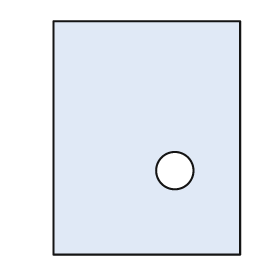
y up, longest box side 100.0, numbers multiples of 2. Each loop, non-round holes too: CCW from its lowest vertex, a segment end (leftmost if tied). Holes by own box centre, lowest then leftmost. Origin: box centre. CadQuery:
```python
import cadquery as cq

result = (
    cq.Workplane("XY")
    .moveTo(-40.0, -50.0)
    .lineTo(40.0, -50.0)
    .lineTo(40.0, 50.0)
    .lineTo(-40.0, 50.0)
    .close()
    .moveTo(12.0, -14.0)
    .circle(8.0)
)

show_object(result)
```